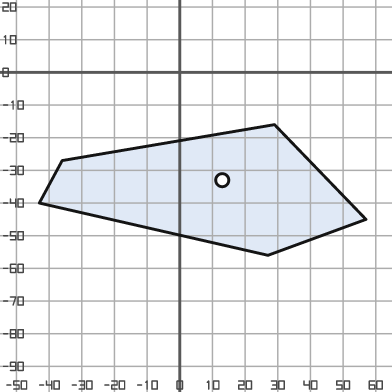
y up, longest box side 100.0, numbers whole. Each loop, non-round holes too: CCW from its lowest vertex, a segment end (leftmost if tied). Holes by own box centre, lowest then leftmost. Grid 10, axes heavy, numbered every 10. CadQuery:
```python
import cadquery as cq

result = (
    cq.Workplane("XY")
    .moveTo(27.0, -56.0)
    .lineTo(57.0, -45.0)
    .lineTo(29.0, -16.0)
    .lineTo(-36.0, -27.0)
    .lineTo(-43.0, -40.0)
    .close()
    .moveTo(13.0, -33.0)
    .circle(2.0)
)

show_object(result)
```